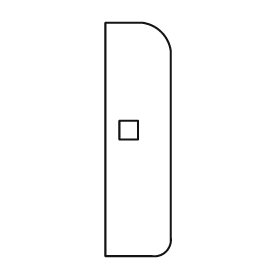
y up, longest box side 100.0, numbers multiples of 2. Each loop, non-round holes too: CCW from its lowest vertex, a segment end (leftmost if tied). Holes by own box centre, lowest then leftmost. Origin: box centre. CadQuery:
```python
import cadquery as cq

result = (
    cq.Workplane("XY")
    .moveTo(-14.0, -50.0)
    .lineTo(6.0, -50.0)
    .threePointArc((12.0, -48.0), (14.0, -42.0))
    .lineTo(14.0, 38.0)
    .threePointArc((10.0, 46.0), (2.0, 50.0))
    .lineTo(-14.0, 50.0)
    .close()
    .moveTo(-8.0, 0.0)
    .lineTo(0.0, 0.0)
    .lineTo(0.0, 8.0)
    .lineTo(-8.0, 8.0)
    .close()
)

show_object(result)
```